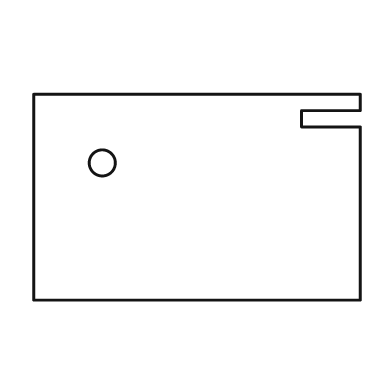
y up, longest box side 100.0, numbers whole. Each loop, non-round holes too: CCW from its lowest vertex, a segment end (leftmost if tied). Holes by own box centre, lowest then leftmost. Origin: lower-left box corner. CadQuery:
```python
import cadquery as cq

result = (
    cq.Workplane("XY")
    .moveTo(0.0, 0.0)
    .lineTo(100.0, 0.0)
    .lineTo(100.0, 53.0)
    .lineTo(82.0, 53.0)
    .lineTo(82.0, 58.0)
    .lineTo(100.0, 58.0)
    .lineTo(100.0, 63.0)
    .lineTo(0.0, 63.0)
    .close()
    .moveTo(21.0, 42.0)
    .circle(4.0)
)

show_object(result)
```